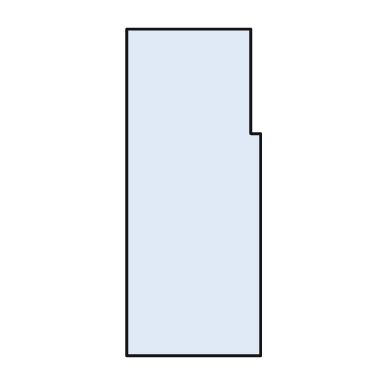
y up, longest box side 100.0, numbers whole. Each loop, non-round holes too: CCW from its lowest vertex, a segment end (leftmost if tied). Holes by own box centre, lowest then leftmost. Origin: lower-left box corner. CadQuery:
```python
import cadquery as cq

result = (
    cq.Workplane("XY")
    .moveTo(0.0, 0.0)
    .lineTo(41.0, 0.0)
    .lineTo(41.0, 68.0)
    .lineTo(38.0, 68.0)
    .lineTo(38.0, 100.0)
    .lineTo(0.0, 100.0)
    .close()
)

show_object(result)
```